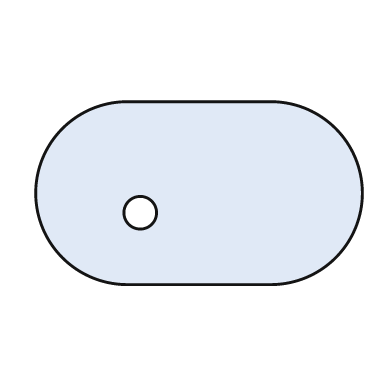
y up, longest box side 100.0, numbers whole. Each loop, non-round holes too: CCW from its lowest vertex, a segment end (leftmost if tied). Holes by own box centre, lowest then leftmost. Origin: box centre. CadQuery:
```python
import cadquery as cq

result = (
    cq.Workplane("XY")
    .moveTo(-22.0, -28.0)
    .lineTo(22.0, -28.0)
    .threePointArc((50.0, 0.0), (22.0, 28.0))
    .lineTo(-22.0, 28.0)
    .threePointArc((-50.0, 0.0), (-22.0, -28.0))
    .close()
    .moveTo(-18.0, -6.0)
    .circle(5.0)
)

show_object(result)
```